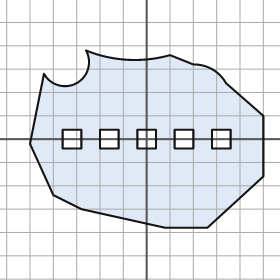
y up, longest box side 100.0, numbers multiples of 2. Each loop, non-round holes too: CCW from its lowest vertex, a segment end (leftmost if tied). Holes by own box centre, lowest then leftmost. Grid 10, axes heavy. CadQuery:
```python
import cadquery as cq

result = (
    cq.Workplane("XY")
    .moveTo(8.0, -38.0)
    .lineTo(26.0, -38.0)
    .lineTo(50.0, -16.0)
    .lineTo(50.0, 10.0)
    .lineTo(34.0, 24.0)
    .threePointArc((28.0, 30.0), (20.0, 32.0))
    .lineTo(10.0, 36.0)
    .threePointArc((-8.0, 34.0), (-26.0, 38.0))
    .threePointArc((-30.0, 24.0), (-44.0, 28.0))
    .lineTo(-50.0, -2.0)
    .lineTo(-40.0, -24.0)
    .lineTo(-28.0, -30.0)
    .close()
    .moveTo(-36.0, -4.0)
    .lineTo(-28.0, -4.0)
    .lineTo(-28.0, 4.0)
    .lineTo(-36.0, 4.0)
    .close()
    .moveTo(-20.0, -4.0)
    .lineTo(-12.0, -4.0)
    .lineTo(-12.0, 4.0)
    .lineTo(-20.0, 4.0)
    .close()
    .moveTo(-4.0, -4.0)
    .lineTo(4.0, -4.0)
    .lineTo(4.0, 4.0)
    .lineTo(-4.0, 4.0)
    .close()
    .moveTo(12.0, -4.0)
    .lineTo(20.0, -4.0)
    .lineTo(20.0, 4.0)
    .lineTo(12.0, 4.0)
    .close()
    .moveTo(28.0, -4.0)
    .lineTo(36.0, -4.0)
    .lineTo(36.0, 4.0)
    .lineTo(28.0, 4.0)
    .close()
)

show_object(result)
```